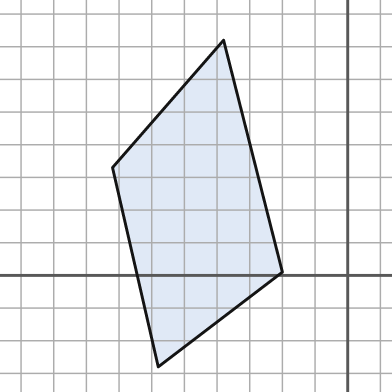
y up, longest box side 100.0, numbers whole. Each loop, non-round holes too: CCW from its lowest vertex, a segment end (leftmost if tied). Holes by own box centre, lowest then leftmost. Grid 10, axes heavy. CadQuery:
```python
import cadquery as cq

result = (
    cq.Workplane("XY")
    .moveTo(-58.0, -28.0)
    .lineTo(-20.0, 1.0)
    .lineTo(-38.0, 72.0)
    .lineTo(-72.0, 33.0)
    .close()
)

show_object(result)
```